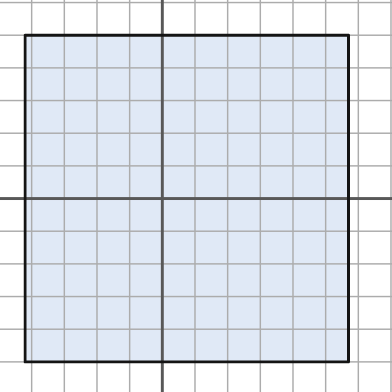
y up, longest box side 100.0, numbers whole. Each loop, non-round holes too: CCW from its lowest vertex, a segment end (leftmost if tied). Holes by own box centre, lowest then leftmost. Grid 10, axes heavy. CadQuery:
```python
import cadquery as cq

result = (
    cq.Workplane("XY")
    .moveTo(-42.0, -50.0)
    .lineTo(57.0, -50.0)
    .lineTo(57.0, 50.0)
    .lineTo(-42.0, 50.0)
    .close()
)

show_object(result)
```